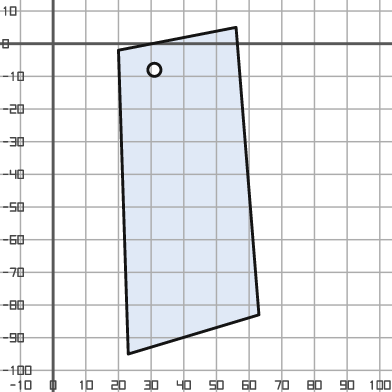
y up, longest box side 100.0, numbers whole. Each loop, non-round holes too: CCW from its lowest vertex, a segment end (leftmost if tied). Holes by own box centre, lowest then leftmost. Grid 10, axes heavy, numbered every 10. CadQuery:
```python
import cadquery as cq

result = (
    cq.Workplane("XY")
    .moveTo(23.0, -95.0)
    .lineTo(63.0, -83.0)
    .lineTo(56.0, 5.0)
    .lineTo(20.0, -2.0)
    .close()
    .moveTo(31.0, -8.0)
    .circle(2.0)
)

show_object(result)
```